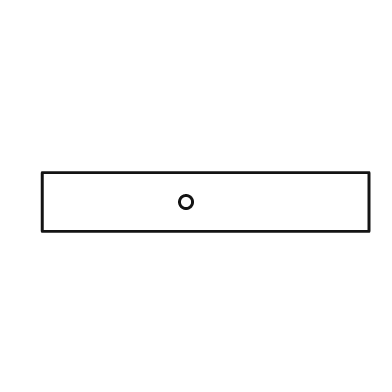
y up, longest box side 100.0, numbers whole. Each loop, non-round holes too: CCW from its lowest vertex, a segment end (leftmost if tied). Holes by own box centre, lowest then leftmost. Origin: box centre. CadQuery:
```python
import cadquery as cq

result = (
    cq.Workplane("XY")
    .moveTo(-50.0, -9.0)
    .lineTo(50.0, -9.0)
    .lineTo(50.0, 9.0)
    .lineTo(-50.0, 9.0)
    .close()
    .moveTo(-6.0, 0.0)
    .circle(2.0)
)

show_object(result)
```